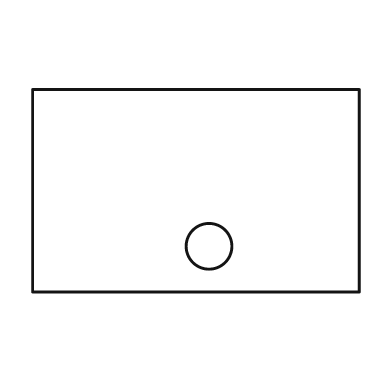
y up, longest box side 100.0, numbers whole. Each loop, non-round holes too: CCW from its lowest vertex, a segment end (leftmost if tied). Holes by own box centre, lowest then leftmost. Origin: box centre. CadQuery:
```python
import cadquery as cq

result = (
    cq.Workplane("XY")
    .moveTo(-50.0, -31.0)
    .lineTo(50.0, -31.0)
    .lineTo(50.0, 31.0)
    .lineTo(-50.0, 31.0)
    .close()
    .moveTo(4.0, -17.0)
    .circle(7.0)
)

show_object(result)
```